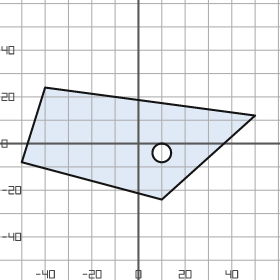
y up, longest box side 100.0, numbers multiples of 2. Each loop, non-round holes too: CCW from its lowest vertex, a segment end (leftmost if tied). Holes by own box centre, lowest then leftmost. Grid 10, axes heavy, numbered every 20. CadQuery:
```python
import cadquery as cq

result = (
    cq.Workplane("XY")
    .moveTo(10.0, -24.0)
    .lineTo(50.0, 12.0)
    .lineTo(-40.0, 24.0)
    .lineTo(-50.0, -8.0)
    .close()
    .moveTo(10.0, -4.0)
    .circle(4.0)
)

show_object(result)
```